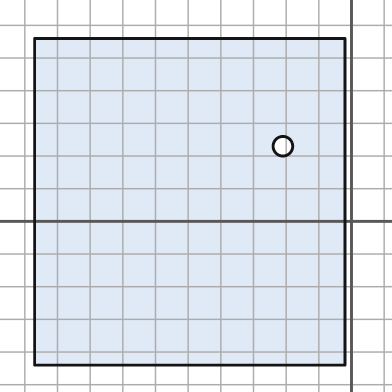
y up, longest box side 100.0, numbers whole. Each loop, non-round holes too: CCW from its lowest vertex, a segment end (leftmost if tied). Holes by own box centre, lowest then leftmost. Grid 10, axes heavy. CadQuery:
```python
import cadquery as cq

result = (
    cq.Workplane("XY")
    .moveTo(-97.0, -44.0)
    .lineTo(-2.0, -44.0)
    .lineTo(-2.0, 56.0)
    .lineTo(-97.0, 56.0)
    .close()
    .moveTo(-21.0, 23.0)
    .circle(3.0)
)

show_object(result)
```